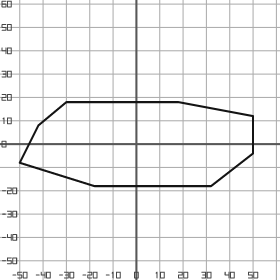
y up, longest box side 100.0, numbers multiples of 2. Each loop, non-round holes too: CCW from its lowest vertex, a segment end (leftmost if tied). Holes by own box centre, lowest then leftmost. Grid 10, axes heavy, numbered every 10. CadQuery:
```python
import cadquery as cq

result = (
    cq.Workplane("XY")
    .moveTo(-18.0, -18.0)
    .lineTo(32.0, -18.0)
    .lineTo(50.0, -4.0)
    .lineTo(50.0, 12.0)
    .lineTo(18.0, 18.0)
    .lineTo(-30.0, 18.0)
    .lineTo(-42.0, 8.0)
    .lineTo(-50.0, -8.0)
    .close()
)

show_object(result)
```